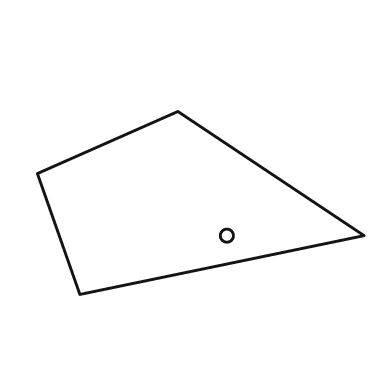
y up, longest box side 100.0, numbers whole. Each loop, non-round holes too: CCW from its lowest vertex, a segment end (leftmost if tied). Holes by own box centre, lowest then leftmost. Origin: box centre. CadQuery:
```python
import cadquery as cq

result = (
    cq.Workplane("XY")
    .moveTo(-37.0, -28.0)
    .lineTo(50.0, -10.0)
    .lineTo(-7.0, 28.0)
    .lineTo(-50.0, 9.0)
    .close()
    .moveTo(8.0, -10.0)
    .circle(2.0)
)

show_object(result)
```